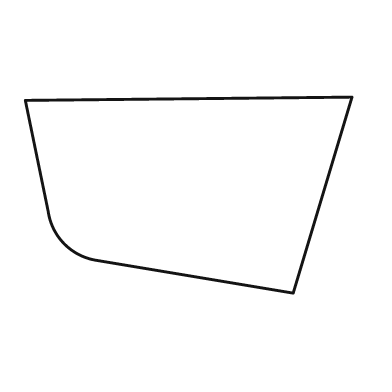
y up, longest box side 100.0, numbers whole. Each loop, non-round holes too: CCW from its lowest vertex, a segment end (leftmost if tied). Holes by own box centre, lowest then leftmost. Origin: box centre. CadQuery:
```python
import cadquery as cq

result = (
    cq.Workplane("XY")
    .moveTo(32.0, -30.0)
    .lineTo(50.0, 30.0)
    .lineTo(-50.0, 29.0)
    .lineTo(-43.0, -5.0)
    .threePointArc((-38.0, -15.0), (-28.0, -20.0))
    .close()
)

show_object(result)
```